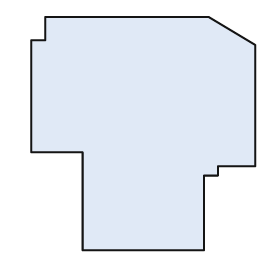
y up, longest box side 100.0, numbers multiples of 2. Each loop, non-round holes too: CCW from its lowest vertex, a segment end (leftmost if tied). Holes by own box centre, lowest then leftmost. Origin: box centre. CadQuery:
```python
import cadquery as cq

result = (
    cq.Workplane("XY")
    .moveTo(-26.0, -50.0)
    .lineTo(26.0, -50.0)
    .lineTo(26.0, -18.0)
    .lineTo(32.0, -18.0)
    .lineTo(32.0, -14.0)
    .lineTo(48.0, -14.0)
    .lineTo(48.0, 38.0)
    .lineTo(28.0, 50.0)
    .lineTo(-42.0, 50.0)
    .lineTo(-42.0, 40.0)
    .lineTo(-48.0, 40.0)
    .lineTo(-48.0, -8.0)
    .lineTo(-26.0, -8.0)
    .close()
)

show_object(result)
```